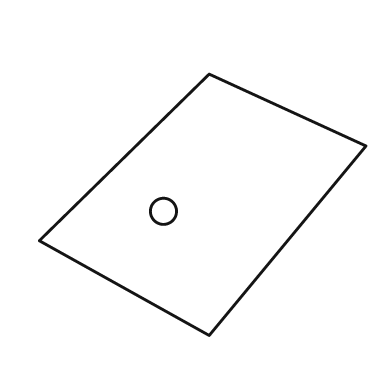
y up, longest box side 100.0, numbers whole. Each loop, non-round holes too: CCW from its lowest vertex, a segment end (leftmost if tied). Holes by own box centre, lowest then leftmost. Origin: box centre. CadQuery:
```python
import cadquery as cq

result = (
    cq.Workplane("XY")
    .moveTo(2.0, -40.0)
    .lineTo(50.0, 18.0)
    .lineTo(2.0, 40.0)
    .lineTo(-50.0, -11.0)
    .close()
    .moveTo(-12.0, -2.0)
    .circle(4.0)
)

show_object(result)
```